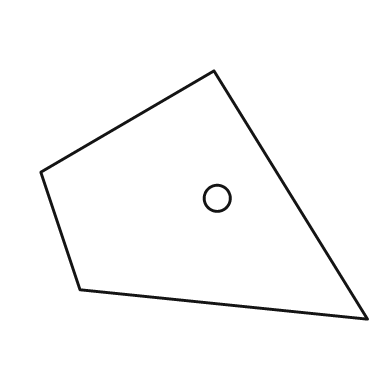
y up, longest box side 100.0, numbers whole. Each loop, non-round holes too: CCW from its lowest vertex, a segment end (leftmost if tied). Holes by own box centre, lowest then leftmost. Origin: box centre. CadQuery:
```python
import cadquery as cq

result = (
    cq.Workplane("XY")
    .moveTo(50.0, -38.0)
    .lineTo(3.0, 38.0)
    .lineTo(-50.0, 7.0)
    .lineTo(-38.0, -29.0)
    .close()
    .moveTo(4.0, -1.0)
    .circle(4.0)
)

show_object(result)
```